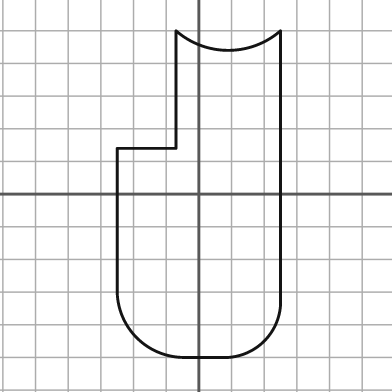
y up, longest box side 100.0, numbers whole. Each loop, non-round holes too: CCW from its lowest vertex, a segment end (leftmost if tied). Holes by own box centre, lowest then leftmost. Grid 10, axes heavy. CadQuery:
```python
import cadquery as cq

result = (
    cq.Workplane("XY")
    .moveTo(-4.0, -50.0)
    .lineTo(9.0, -50.0)
    .threePointArc((20.0, -45.0), (25.0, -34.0))
    .lineTo(25.0, 50.0)
    .threePointArc((9.0, 44.0), (-7.0, 50.0))
    .lineTo(-7.0, 14.0)
    .lineTo(-25.0, 14.0)
    .lineTo(-25.0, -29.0)
    .threePointArc((-19.0, -44.0), (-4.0, -50.0))
    .close()
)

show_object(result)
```